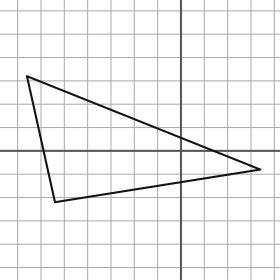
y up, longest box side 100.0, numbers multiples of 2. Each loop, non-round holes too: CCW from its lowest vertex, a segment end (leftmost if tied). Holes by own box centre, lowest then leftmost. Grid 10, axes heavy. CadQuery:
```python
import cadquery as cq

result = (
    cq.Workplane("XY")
    .moveTo(-54.0, -22.0)
    .lineTo(34.0, -8.0)
    .lineTo(-66.0, 32.0)
    .close()
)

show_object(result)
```